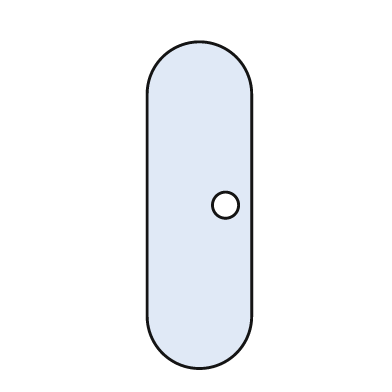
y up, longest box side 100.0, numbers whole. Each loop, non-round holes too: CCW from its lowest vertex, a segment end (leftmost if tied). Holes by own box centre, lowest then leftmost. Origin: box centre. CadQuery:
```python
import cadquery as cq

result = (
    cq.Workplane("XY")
    .moveTo(-16.0, -34.0)
    .threePointArc((0.0, -50.0), (16.0, -34.0))
    .lineTo(16.0, 34.0)
    .threePointArc((0.0, 50.0), (-16.0, 34.0))
    .close()
    .moveTo(8.0, 0.0)
    .circle(4.0)
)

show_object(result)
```